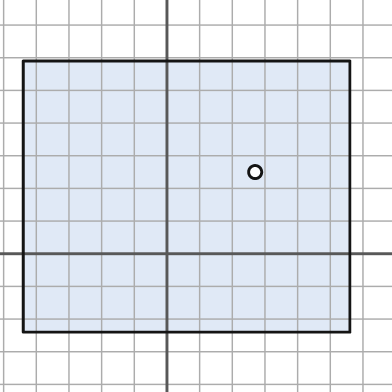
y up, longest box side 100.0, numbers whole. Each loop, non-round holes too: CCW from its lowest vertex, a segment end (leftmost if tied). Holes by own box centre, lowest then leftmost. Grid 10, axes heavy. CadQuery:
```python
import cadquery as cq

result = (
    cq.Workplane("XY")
    .moveTo(-44.0, -24.0)
    .lineTo(56.0, -24.0)
    .lineTo(56.0, 59.0)
    .lineTo(-44.0, 59.0)
    .close()
    .moveTo(27.0, 25.0)
    .circle(2.0)
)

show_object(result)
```